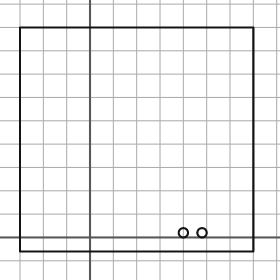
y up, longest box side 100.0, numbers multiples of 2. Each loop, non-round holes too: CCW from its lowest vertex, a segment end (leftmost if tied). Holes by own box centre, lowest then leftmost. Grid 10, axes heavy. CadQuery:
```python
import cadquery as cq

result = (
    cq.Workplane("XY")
    .moveTo(-30.0, -6.0)
    .lineTo(70.0, -6.0)
    .lineTo(70.0, 90.0)
    .lineTo(-30.0, 90.0)
    .close()
    .moveTo(40.0, 2.0)
    .circle(2.0)
    .moveTo(48.0, 2.0)
    .circle(2.0)
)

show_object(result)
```